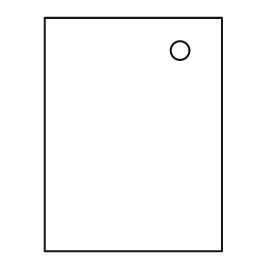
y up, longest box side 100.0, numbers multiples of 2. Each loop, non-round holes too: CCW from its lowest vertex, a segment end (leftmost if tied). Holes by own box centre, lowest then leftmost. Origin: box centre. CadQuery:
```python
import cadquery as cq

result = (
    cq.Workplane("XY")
    .moveTo(-38.0, -50.0)
    .lineTo(38.0, -50.0)
    .lineTo(38.0, 50.0)
    .lineTo(-38.0, 50.0)
    .close()
    .moveTo(20.0, 36.0)
    .circle(4.0)
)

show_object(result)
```